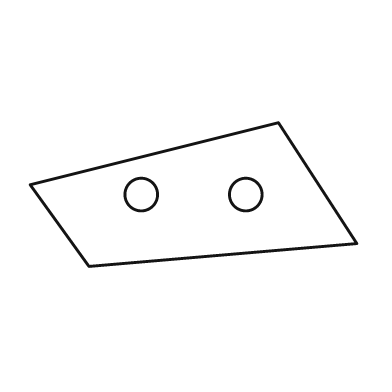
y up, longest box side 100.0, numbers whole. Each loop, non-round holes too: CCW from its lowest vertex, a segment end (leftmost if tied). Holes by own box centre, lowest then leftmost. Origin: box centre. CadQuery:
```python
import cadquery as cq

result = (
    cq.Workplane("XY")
    .moveTo(-32.0, -22.0)
    .lineTo(50.0, -15.0)
    .lineTo(26.0, 22.0)
    .lineTo(-50.0, 3.0)
    .close()
    .moveTo(-16.0, 0.0)
    .circle(5.0)
    .moveTo(16.0, 0.0)
    .circle(5.0)
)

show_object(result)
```